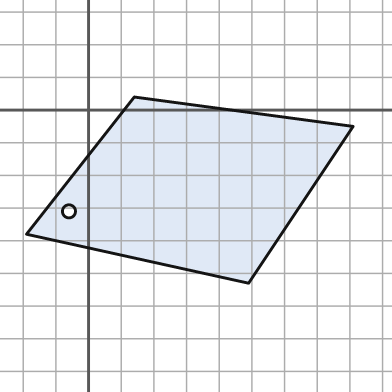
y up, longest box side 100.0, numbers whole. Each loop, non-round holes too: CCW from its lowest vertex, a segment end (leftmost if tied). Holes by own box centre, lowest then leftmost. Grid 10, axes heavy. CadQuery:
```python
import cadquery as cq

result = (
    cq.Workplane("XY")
    .moveTo(49.0, -53.0)
    .lineTo(81.0, -5.0)
    .lineTo(14.0, 4.0)
    .lineTo(-19.0, -38.0)
    .close()
    .moveTo(-6.0, -31.0)
    .circle(2.0)
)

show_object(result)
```